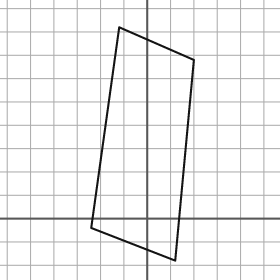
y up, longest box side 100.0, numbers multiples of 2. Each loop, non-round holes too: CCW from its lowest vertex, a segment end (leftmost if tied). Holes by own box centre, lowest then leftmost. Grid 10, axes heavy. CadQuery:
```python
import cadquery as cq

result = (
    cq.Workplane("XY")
    .moveTo(12.0, -18.0)
    .lineTo(20.0, 68.0)
    .lineTo(-12.0, 82.0)
    .lineTo(-24.0, -4.0)
    .close()
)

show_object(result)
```